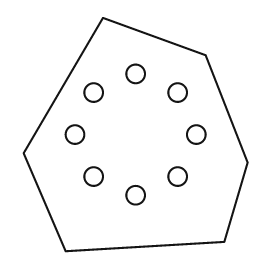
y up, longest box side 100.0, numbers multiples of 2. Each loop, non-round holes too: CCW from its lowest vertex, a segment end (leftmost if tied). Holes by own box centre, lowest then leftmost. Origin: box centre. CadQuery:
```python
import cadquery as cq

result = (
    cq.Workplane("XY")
    .moveTo(-30.0, -50.0)
    .lineTo(38.0, -46.0)
    .lineTo(48.0, -12.0)
    .lineTo(30.0, 34.0)
    .lineTo(-14.0, 50.0)
    .lineTo(-48.0, -8.0)
    .close()
    .moveTo(0.0, -26.0)
    .circle(4.0)
    .moveTo(-18.0, -18.0)
    .circle(4.0)
    .moveTo(18.0, -18.0)
    .circle(4.0)
    .moveTo(-26.0, 0.0)
    .circle(4.0)
    .moveTo(26.0, 0.0)
    .circle(4.0)
    .moveTo(-18.0, 18.0)
    .circle(4.0)
    .moveTo(18.0, 18.0)
    .circle(4.0)
    .moveTo(0.0, 26.0)
    .circle(4.0)
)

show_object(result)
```